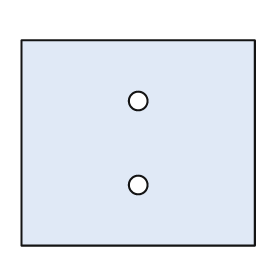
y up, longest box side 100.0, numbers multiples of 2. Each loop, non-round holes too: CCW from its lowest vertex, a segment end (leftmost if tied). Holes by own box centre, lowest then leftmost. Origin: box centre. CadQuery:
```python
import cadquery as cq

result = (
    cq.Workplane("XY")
    .moveTo(-50.0, -44.0)
    .lineTo(50.0, -44.0)
    .lineTo(50.0, 44.0)
    .lineTo(-50.0, 44.0)
    .close()
    .moveTo(0.0, -18.0)
    .circle(4.0)
    .moveTo(0.0, 18.0)
    .circle(4.0)
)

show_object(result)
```